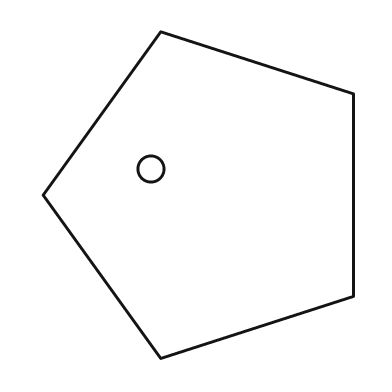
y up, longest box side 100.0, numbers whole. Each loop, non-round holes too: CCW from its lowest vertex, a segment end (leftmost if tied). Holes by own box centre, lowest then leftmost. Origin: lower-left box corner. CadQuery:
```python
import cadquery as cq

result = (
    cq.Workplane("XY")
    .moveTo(36.0, 0.0)
    .lineTo(95.0, 19.0)
    .lineTo(95.0, 81.0)
    .lineTo(36.0, 100.0)
    .lineTo(0.0, 50.0)
    .close()
    .moveTo(33.0, 58.0)
    .circle(4.0)
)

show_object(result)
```